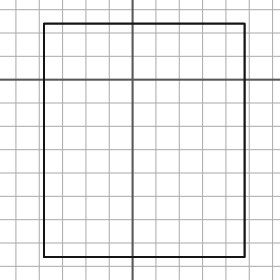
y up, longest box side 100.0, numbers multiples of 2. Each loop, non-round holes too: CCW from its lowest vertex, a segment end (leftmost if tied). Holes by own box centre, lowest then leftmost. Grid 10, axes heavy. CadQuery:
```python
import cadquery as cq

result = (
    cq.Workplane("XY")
    .moveTo(-38.0, -76.0)
    .lineTo(48.0, -76.0)
    .lineTo(48.0, 24.0)
    .lineTo(-38.0, 24.0)
    .close()
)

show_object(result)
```